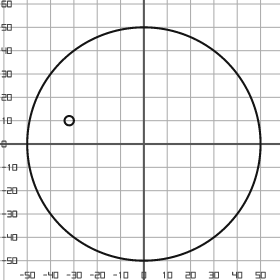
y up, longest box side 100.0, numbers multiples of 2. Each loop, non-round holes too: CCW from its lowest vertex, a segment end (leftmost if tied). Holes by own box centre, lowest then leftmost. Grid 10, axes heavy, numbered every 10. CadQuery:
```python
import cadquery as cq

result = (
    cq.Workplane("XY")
    .moveTo(0.0, 0.0)
    .circle(50.0)
    .moveTo(-32.0, 10.0)
    .circle(2.0)
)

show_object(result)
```